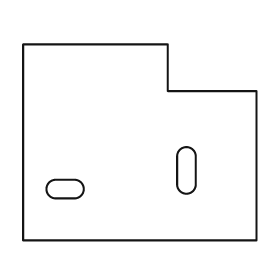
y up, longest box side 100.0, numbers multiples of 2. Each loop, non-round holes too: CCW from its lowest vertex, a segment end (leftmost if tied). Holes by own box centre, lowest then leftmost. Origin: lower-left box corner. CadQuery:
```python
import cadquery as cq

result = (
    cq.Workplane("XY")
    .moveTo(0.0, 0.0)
    .lineTo(100.0, 0.0)
    .lineTo(100.0, 64.0)
    .lineTo(62.0, 64.0)
    .lineTo(62.0, 84.0)
    .lineTo(0.0, 84.0)
    .close()
    .moveTo(14.0, 18.0)
    .lineTo(22.0, 18.0)
    .threePointArc((26.0, 22.0), (22.0, 26.0))
    .lineTo(14.0, 26.0)
    .threePointArc((10.0, 22.0), (14.0, 18.0))
    .close()
    .moveTo(66.0, 24.0)
    .threePointArc((70.0, 20.0), (74.0, 24.0))
    .lineTo(74.0, 36.0)
    .threePointArc((70.0, 40.0), (66.0, 36.0))
    .close()
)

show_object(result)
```